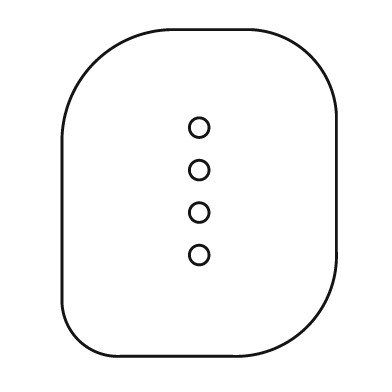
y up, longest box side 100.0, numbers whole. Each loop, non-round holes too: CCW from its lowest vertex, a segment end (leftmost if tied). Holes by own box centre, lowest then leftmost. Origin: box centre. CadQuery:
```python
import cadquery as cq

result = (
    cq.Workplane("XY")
    .moveTo(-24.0, -50.0)
    .lineTo(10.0, -50.0)
    .threePointArc((33.0, -41.0), (42.0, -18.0))
    .lineTo(42.0, 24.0)
    .threePointArc((34.0, 42.0), (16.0, 50.0))
    .lineTo(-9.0, 50.0)
    .threePointArc((-32.0, 40.0), (-42.0, 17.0))
    .lineTo(-42.0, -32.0)
    .threePointArc((-37.0, -45.0), (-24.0, -50.0))
    .close()
    .moveTo(0.0, -19.0)
    .circle(3.0)
    .moveTo(0.0, -6.0)
    .circle(3.0)
    .moveTo(0.0, 7.0)
    .circle(3.0)
    .moveTo(0.0, 20.0)
    .circle(3.0)
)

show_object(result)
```